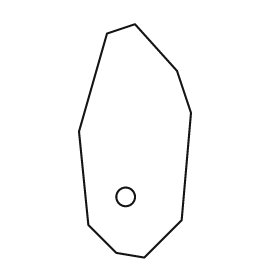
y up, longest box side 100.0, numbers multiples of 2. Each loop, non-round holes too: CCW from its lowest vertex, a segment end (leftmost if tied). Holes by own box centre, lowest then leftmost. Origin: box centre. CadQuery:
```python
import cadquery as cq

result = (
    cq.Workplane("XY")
    .moveTo(4.0, -50.0)
    .lineTo(20.0, -34.0)
    .lineTo(24.0, 12.0)
    .lineTo(18.0, 30.0)
    .lineTo(0.0, 50.0)
    .lineTo(-12.0, 46.0)
    .lineTo(-24.0, 4.0)
    .lineTo(-20.0, -36.0)
    .lineTo(-8.0, -48.0)
    .close()
    .moveTo(-4.0, -24.0)
    .circle(4.0)
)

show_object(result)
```